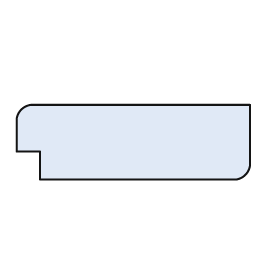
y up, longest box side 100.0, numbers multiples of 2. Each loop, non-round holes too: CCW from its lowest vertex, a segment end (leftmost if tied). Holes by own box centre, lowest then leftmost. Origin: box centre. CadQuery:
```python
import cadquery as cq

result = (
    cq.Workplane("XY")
    .moveTo(-40.0, -16.0)
    .lineTo(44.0, -16.0)
    .threePointArc((48.0, -14.0), (50.0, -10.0))
    .lineTo(50.0, 16.0)
    .lineTo(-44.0, 16.0)
    .threePointArc((-48.0, 14.0), (-50.0, 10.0))
    .lineTo(-50.0, -4.0)
    .lineTo(-40.0, -4.0)
    .close()
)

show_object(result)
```